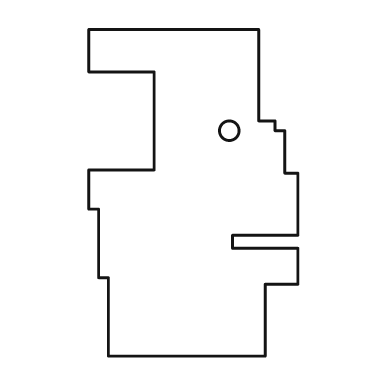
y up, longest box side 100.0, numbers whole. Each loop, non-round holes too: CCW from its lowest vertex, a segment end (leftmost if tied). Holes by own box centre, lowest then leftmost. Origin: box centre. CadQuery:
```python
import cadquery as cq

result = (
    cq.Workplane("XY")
    .moveTo(-26.0, -50.0)
    .lineTo(22.0, -50.0)
    .lineTo(22.0, -28.0)
    .lineTo(32.0, -28.0)
    .lineTo(32.0, -17.0)
    .lineTo(12.0, -17.0)
    .lineTo(12.0, -13.0)
    .lineTo(32.0, -13.0)
    .lineTo(32.0, 6.0)
    .lineTo(28.0, 6.0)
    .lineTo(28.0, 19.0)
    .lineTo(25.0, 19.0)
    .lineTo(25.0, 22.0)
    .lineTo(20.0, 22.0)
    .lineTo(20.0, 50.0)
    .lineTo(-32.0, 50.0)
    .lineTo(-32.0, 37.0)
    .lineTo(-12.0, 37.0)
    .lineTo(-12.0, 7.0)
    .lineTo(-32.0, 7.0)
    .lineTo(-32.0, -5.0)
    .lineTo(-29.0, -5.0)
    .lineTo(-29.0, -26.0)
    .lineTo(-26.0, -26.0)
    .close()
    .moveTo(11.0, 19.0)
    .circle(3.0)
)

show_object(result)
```